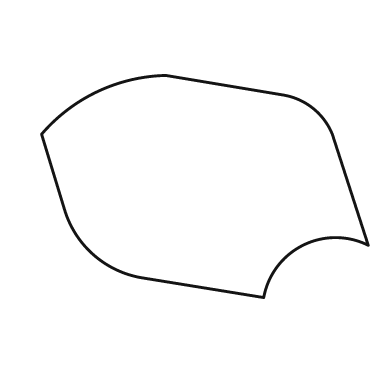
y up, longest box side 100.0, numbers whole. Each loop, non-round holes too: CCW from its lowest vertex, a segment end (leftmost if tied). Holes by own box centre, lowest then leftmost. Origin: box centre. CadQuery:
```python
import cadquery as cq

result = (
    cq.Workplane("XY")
    .moveTo(18.0, -34.0)
    .threePointArc((30.0, -18.0), (50.0, -18.0))
    .lineTo(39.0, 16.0)
    .threePointArc((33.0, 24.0), (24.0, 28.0))
    .lineTo(-12.0, 34.0)
    .threePointArc((-33.0, 29.0), (-50.0, 16.0))
    .lineTo(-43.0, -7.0)
    .threePointArc((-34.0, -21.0), (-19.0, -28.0))
    .close()
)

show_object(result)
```